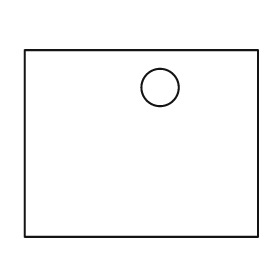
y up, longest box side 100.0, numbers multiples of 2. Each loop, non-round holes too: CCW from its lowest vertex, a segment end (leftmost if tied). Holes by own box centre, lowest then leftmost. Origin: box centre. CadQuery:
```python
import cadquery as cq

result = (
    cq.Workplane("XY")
    .moveTo(-50.0, -40.0)
    .lineTo(50.0, -40.0)
    .lineTo(50.0, 40.0)
    .lineTo(-50.0, 40.0)
    .close()
    .moveTo(8.0, 24.0)
    .circle(8.0)
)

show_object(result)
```